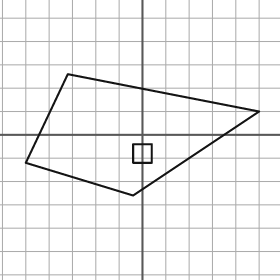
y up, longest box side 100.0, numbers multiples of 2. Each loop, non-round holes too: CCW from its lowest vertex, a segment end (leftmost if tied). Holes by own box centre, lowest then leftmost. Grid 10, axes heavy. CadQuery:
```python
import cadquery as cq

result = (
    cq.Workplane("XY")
    .moveTo(-4.0, -26.0)
    .lineTo(50.0, 10.0)
    .lineTo(-32.0, 26.0)
    .lineTo(-50.0, -12.0)
    .close()
    .moveTo(-4.0, -12.0)
    .lineTo(4.0, -12.0)
    .lineTo(4.0, -4.0)
    .lineTo(-4.0, -4.0)
    .close()
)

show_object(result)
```